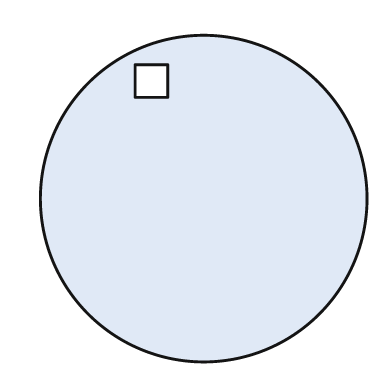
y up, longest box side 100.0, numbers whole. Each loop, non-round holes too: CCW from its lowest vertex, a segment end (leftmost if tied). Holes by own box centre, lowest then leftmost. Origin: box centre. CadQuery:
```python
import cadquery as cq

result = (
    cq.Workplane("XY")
    .moveTo(0.0, 0.0)
    .circle(50.0)
    .moveTo(-21.0, 31.0)
    .lineTo(-11.0, 31.0)
    .lineTo(-11.0, 41.0)
    .lineTo(-21.0, 41.0)
    .close()
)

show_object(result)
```